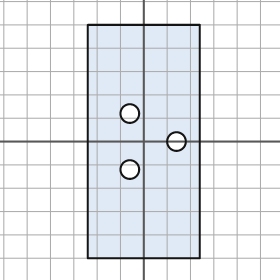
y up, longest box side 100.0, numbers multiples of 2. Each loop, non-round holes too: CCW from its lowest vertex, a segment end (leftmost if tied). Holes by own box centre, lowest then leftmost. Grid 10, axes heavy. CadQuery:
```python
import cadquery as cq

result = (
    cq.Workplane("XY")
    .moveTo(-24.0, -50.0)
    .lineTo(24.0, -50.0)
    .lineTo(24.0, 50.0)
    .lineTo(-24.0, 50.0)
    .close()
    .moveTo(-6.0, -12.0)
    .circle(4.0)
    .moveTo(14.0, 0.0)
    .circle(4.0)
    .moveTo(-6.0, 12.0)
    .circle(4.0)
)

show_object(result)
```